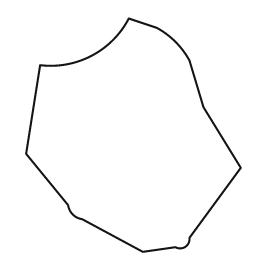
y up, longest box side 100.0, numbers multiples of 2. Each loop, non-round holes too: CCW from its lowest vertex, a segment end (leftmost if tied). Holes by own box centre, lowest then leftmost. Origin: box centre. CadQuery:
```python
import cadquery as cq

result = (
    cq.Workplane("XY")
    .moveTo(4.0, -50.0)
    .lineTo(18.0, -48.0)
    .threePointArc((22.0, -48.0), (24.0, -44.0))
    .lineTo(46.0, -14.0)
    .lineTo(30.0, 12.0)
    .lineTo(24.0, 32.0)
    .threePointArc((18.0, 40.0), (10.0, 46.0))
    .lineTo(-2.0, 50.0)
    .threePointArc((-18.0, 34.0), (-40.0, 30.0))
    .lineTo(-46.0, -8.0)
    .lineTo(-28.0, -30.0)
    .threePointArc((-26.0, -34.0), (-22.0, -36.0))
    .close()
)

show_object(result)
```